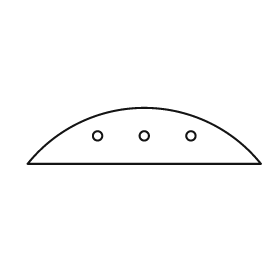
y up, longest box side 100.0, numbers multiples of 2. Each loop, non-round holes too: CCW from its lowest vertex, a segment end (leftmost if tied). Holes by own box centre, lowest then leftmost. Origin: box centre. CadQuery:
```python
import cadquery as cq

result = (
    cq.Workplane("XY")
    .moveTo(-50.0, -12.0)
    .lineTo(50.0, -12.0)
    .threePointArc((0.0, 12.0), (-50.0, -12.0))
    .close()
    .moveTo(-20.0, 0.0)
    .circle(2.0)
    .moveTo(0.0, 0.0)
    .circle(2.0)
    .moveTo(20.0, 0.0)
    .circle(2.0)
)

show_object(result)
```